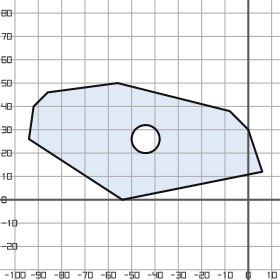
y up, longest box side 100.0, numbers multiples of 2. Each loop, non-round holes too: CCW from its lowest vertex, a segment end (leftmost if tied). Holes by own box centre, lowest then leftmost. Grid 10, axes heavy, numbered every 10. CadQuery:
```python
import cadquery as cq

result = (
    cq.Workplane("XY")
    .moveTo(-54.0, 0.0)
    .lineTo(6.0, 12.0)
    .lineTo(0.0, 30.0)
    .lineTo(-8.0, 38.0)
    .lineTo(-56.0, 50.0)
    .lineTo(-86.0, 46.0)
    .lineTo(-92.0, 40.0)
    .lineTo(-94.0, 26.0)
    .close()
    .moveTo(-44.0, 26.0)
    .circle(6.0)
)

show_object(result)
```